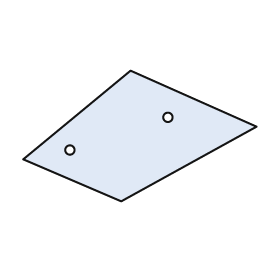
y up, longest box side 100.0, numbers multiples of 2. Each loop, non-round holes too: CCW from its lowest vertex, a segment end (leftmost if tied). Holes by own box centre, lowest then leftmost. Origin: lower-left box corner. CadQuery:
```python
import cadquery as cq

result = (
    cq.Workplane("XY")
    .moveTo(42.0, 0.0)
    .lineTo(100.0, 32.0)
    .lineTo(46.0, 56.0)
    .lineTo(0.0, 18.0)
    .close()
    .moveTo(20.0, 22.0)
    .circle(2.0)
    .moveTo(62.0, 36.0)
    .circle(2.0)
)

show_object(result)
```